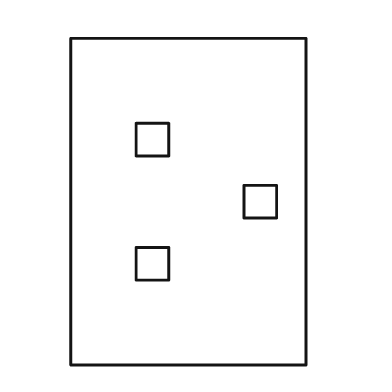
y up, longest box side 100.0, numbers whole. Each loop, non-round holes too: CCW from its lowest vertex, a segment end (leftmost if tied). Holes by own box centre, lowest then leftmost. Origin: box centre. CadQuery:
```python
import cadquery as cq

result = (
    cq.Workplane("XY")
    .moveTo(-36.0, -50.0)
    .lineTo(36.0, -50.0)
    .lineTo(36.0, 50.0)
    .lineTo(-36.0, 50.0)
    .close()
    .moveTo(-16.0, -24.0)
    .lineTo(-6.0, -24.0)
    .lineTo(-6.0, -14.0)
    .lineTo(-16.0, -14.0)
    .close()
    .moveTo(17.0, -5.0)
    .lineTo(27.0, -5.0)
    .lineTo(27.0, 5.0)
    .lineTo(17.0, 5.0)
    .close()
    .moveTo(-16.0, 14.0)
    .lineTo(-6.0, 14.0)
    .lineTo(-6.0, 24.0)
    .lineTo(-16.0, 24.0)
    .close()
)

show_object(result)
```